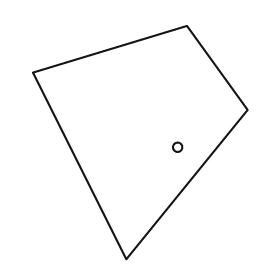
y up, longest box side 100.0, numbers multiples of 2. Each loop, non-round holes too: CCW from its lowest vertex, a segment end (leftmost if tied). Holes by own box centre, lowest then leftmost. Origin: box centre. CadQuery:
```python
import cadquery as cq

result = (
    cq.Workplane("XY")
    .moveTo(-6.0, -50.0)
    .lineTo(46.0, 14.0)
    .lineTo(20.0, 50.0)
    .lineTo(-46.0, 30.0)
    .close()
    .moveTo(16.0, -2.0)
    .circle(2.0)
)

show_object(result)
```